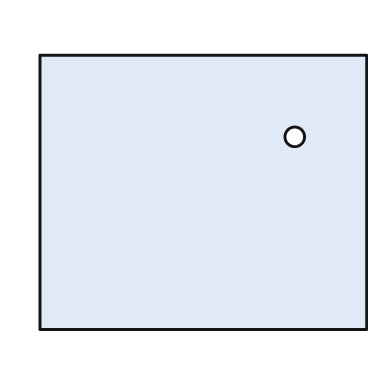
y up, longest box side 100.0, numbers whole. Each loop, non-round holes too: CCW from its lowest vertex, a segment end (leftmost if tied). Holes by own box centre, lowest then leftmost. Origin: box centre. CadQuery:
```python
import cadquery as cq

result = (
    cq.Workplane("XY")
    .moveTo(-50.0, -42.0)
    .lineTo(50.0, -42.0)
    .lineTo(50.0, 42.0)
    .lineTo(-50.0, 42.0)
    .close()
    .moveTo(28.0, 17.0)
    .circle(3.0)
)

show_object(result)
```